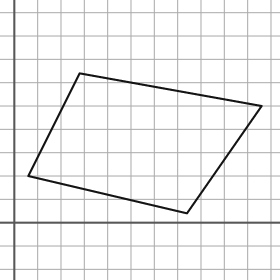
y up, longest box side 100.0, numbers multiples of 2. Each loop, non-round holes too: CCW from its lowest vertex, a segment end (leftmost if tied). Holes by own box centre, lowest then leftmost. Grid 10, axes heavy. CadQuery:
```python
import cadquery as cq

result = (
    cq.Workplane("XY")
    .moveTo(74.0, 4.0)
    .lineTo(106.0, 50.0)
    .lineTo(28.0, 64.0)
    .lineTo(6.0, 20.0)
    .close()
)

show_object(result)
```